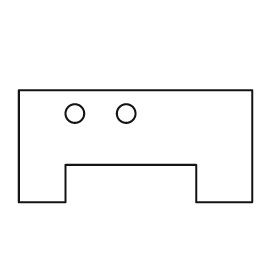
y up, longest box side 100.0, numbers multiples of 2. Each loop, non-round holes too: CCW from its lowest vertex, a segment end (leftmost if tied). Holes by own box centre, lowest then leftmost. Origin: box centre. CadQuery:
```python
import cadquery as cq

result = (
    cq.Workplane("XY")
    .moveTo(-50.0, -24.0)
    .lineTo(-30.0, -24.0)
    .lineTo(-30.0, -8.0)
    .lineTo(26.0, -8.0)
    .lineTo(26.0, -24.0)
    .lineTo(50.0, -24.0)
    .lineTo(50.0, 24.0)
    .lineTo(-50.0, 24.0)
    .close()
    .moveTo(-26.0, 14.0)
    .circle(4.0)
    .moveTo(-4.0, 14.0)
    .circle(4.0)
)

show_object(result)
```